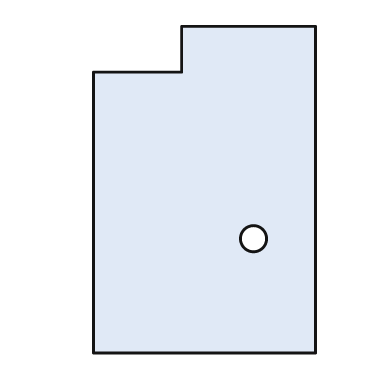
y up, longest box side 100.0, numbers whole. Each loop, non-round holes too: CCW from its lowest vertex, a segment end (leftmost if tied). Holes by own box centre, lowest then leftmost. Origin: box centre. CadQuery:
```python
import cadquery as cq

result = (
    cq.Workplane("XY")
    .moveTo(-34.0, -50.0)
    .lineTo(34.0, -50.0)
    .lineTo(34.0, 50.0)
    .lineTo(-7.0, 50.0)
    .lineTo(-7.0, 36.0)
    .lineTo(-34.0, 36.0)
    .close()
    .moveTo(15.0, -15.0)
    .circle(4.0)
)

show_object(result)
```